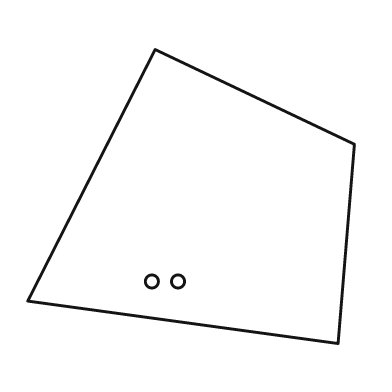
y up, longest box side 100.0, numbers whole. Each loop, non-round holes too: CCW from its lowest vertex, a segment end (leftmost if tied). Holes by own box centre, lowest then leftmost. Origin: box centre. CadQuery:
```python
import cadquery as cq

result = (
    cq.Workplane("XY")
    .moveTo(45.0, -45.0)
    .lineTo(50.0, 16.0)
    .lineTo(-11.0, 45.0)
    .lineTo(-50.0, -32.0)
    .close()
    .moveTo(-12.0, -26.0)
    .circle(2.0)
    .moveTo(-4.0, -26.0)
    .circle(2.0)
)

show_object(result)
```